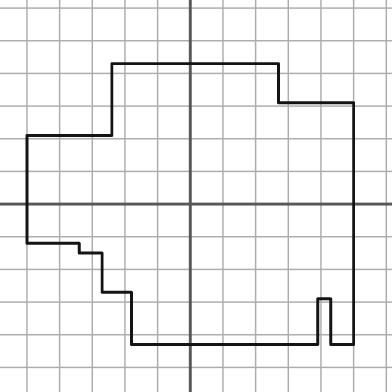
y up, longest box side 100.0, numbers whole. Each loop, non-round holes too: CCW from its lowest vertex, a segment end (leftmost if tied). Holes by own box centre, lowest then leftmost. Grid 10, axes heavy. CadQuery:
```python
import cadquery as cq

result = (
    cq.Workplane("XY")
    .moveTo(-18.0, -43.0)
    .lineTo(39.0, -43.0)
    .lineTo(39.0, -29.0)
    .lineTo(43.0, -29.0)
    .lineTo(43.0, -43.0)
    .lineTo(50.0, -43.0)
    .lineTo(50.0, 31.0)
    .lineTo(27.0, 31.0)
    .lineTo(27.0, 43.0)
    .lineTo(-24.0, 43.0)
    .lineTo(-24.0, 21.0)
    .lineTo(-50.0, 21.0)
    .lineTo(-50.0, -12.0)
    .lineTo(-34.0, -12.0)
    .lineTo(-34.0, -15.0)
    .lineTo(-27.0, -15.0)
    .lineTo(-27.0, -27.0)
    .lineTo(-18.0, -27.0)
    .close()
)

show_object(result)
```